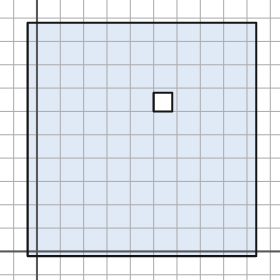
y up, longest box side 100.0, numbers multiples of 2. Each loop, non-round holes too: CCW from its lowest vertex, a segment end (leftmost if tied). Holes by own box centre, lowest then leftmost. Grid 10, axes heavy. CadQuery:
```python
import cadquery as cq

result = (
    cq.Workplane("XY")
    .moveTo(-4.0, -2.0)
    .lineTo(94.0, -2.0)
    .lineTo(94.0, 98.0)
    .lineTo(-4.0, 98.0)
    .close()
    .moveTo(50.0, 60.0)
    .lineTo(58.0, 60.0)
    .lineTo(58.0, 68.0)
    .lineTo(50.0, 68.0)
    .close()
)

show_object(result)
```